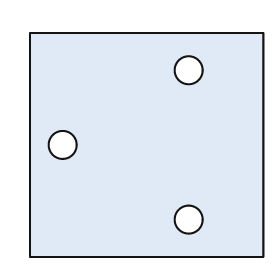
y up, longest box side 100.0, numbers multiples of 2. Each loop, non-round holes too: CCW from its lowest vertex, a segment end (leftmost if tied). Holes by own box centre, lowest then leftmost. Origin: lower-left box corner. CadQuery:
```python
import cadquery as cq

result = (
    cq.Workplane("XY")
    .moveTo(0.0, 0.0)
    .lineTo(100.0, 0.0)
    .lineTo(100.0, 96.0)
    .lineTo(0.0, 96.0)
    .close()
    .moveTo(68.0, 16.0)
    .circle(6.0)
    .moveTo(14.0, 48.0)
    .circle(6.0)
    .moveTo(68.0, 80.0)
    .circle(6.0)
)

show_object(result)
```